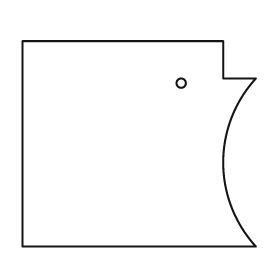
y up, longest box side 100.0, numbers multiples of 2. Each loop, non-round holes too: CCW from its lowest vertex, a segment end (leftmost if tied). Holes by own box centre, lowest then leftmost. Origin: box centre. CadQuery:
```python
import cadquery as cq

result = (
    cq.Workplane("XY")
    .moveTo(-50.0, -44.0)
    .lineTo(50.0, -44.0)
    .threePointArc((36.0, -8.0), (50.0, 28.0))
    .lineTo(36.0, 28.0)
    .lineTo(36.0, 44.0)
    .lineTo(-50.0, 44.0)
    .close()
    .moveTo(18.0, 26.0)
    .circle(2.0)
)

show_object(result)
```